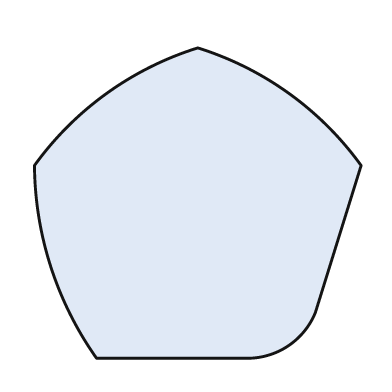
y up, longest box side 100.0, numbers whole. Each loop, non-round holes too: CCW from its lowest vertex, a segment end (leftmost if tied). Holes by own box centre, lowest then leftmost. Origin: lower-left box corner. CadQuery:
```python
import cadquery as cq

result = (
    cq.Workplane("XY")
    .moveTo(19.0, 0.0)
    .lineTo(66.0, 0.0)
    .threePointArc((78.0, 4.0), (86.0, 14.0))
    .lineTo(100.0, 59.0)
    .threePointArc((78.0, 81.0), (50.0, 95.0))
    .threePointArc((22.0, 81.0), (0.0, 59.0))
    .threePointArc((5.0, 28.0), (19.0, 0.0))
    .close()
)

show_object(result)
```